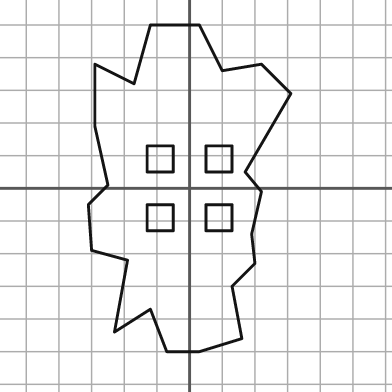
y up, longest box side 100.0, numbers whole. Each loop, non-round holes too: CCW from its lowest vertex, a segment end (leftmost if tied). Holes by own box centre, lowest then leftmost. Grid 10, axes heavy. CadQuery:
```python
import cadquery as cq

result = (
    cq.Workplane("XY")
    .moveTo(-7.0, -50.0)
    .lineTo(3.0, -50.0)
    .lineTo(16.0, -46.0)
    .lineTo(13.0, -30.0)
    .lineTo(20.0, -23.0)
    .lineTo(19.0, -14.0)
    .lineTo(22.0, -1.0)
    .lineTo(17.0, 5.0)
    .lineTo(31.0, 29.0)
    .lineTo(22.0, 38.0)
    .lineTo(10.0, 36.0)
    .lineTo(3.0, 50.0)
    .lineTo(-12.0, 50.0)
    .lineTo(-17.0, 32.0)
    .lineTo(-29.0, 38.0)
    .lineTo(-29.0, 19.0)
    .lineTo(-25.0, 1.0)
    .lineTo(-31.0, -5.0)
    .lineTo(-30.0, -19.0)
    .lineTo(-19.0, -22.0)
    .lineTo(-23.0, -44.0)
    .lineTo(-12.0, -37.0)
    .close()
    .moveTo(-13.0, -13.0)
    .lineTo(-5.0, -13.0)
    .lineTo(-5.0, -5.0)
    .lineTo(-13.0, -5.0)
    .close()
    .moveTo(5.0, -13.0)
    .lineTo(13.0, -13.0)
    .lineTo(13.0, -5.0)
    .lineTo(5.0, -5.0)
    .close()
    .moveTo(-13.0, 5.0)
    .lineTo(-5.0, 5.0)
    .lineTo(-5.0, 13.0)
    .lineTo(-13.0, 13.0)
    .close()
    .moveTo(5.0, 5.0)
    .lineTo(13.0, 5.0)
    .lineTo(13.0, 13.0)
    .lineTo(5.0, 13.0)
    .close()
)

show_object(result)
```